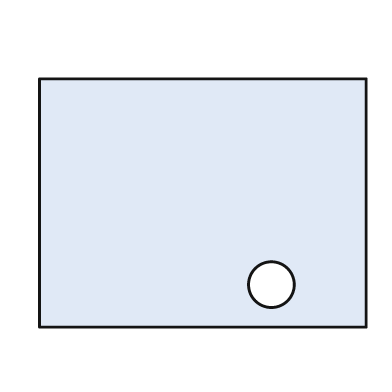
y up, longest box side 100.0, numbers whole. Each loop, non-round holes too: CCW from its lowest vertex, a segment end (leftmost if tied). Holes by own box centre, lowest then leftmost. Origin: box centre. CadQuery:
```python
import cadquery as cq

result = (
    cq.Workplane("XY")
    .moveTo(-50.0, -38.0)
    .lineTo(50.0, -38.0)
    .lineTo(50.0, 38.0)
    .lineTo(-50.0, 38.0)
    .close()
    .moveTo(21.0, -25.0)
    .circle(7.0)
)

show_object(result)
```